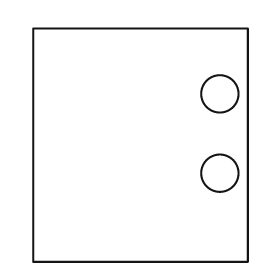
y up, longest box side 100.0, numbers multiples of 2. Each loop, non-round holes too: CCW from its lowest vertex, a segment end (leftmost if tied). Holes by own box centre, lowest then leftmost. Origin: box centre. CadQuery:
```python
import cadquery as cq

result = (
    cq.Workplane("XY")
    .moveTo(-46.0, -50.0)
    .lineTo(46.0, -50.0)
    .lineTo(46.0, 50.0)
    .lineTo(-46.0, 50.0)
    .close()
    .moveTo(34.0, -12.0)
    .circle(8.0)
    .moveTo(34.0, 22.0)
    .circle(8.0)
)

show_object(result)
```